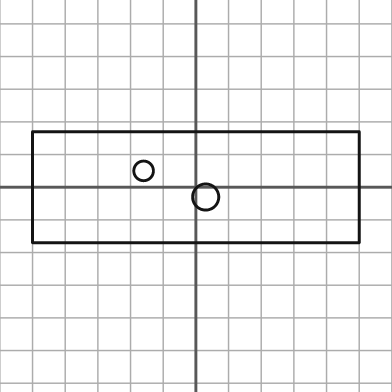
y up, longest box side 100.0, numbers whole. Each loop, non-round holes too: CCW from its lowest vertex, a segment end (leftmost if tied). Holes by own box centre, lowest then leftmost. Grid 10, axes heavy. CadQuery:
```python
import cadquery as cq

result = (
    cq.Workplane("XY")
    .moveTo(-50.0, -17.0)
    .lineTo(50.0, -17.0)
    .lineTo(50.0, 17.0)
    .lineTo(-50.0, 17.0)
    .close()
    .moveTo(3.0, -3.0)
    .circle(4.0)
    .moveTo(-16.0, 5.0)
    .circle(3.0)
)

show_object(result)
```